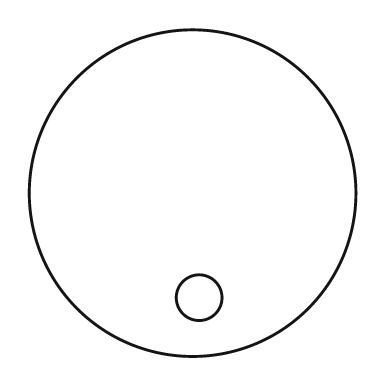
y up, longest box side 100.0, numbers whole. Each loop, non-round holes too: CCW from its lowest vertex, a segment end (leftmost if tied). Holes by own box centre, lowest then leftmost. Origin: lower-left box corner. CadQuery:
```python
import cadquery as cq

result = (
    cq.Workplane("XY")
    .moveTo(50.0, 50.0)
    .circle(50.0)
    .moveTo(52.0, 18.0)
    .circle(7.0)
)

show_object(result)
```